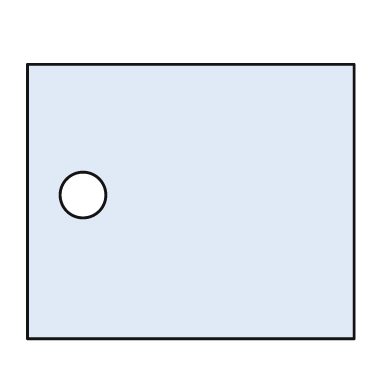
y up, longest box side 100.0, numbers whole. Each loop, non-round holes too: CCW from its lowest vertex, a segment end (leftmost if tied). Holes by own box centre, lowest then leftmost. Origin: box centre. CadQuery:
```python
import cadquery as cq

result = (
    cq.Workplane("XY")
    .moveTo(-50.0, -42.0)
    .lineTo(50.0, -42.0)
    .lineTo(50.0, 42.0)
    .lineTo(-50.0, 42.0)
    .close()
    .moveTo(-33.0, 2.0)
    .circle(7.0)
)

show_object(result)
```